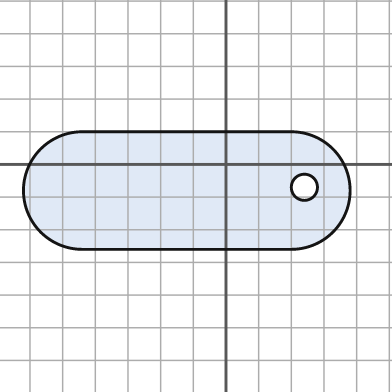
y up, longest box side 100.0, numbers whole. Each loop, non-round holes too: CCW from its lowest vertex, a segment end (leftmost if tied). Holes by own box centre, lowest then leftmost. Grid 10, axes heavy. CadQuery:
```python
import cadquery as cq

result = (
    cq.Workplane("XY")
    .moveTo(-44.0, -26.0)
    .lineTo(20.0, -26.0)
    .threePointArc((38.0, -8.0), (20.0, 10.0))
    .lineTo(-44.0, 10.0)
    .threePointArc((-62.0, -8.0), (-44.0, -26.0))
    .close()
    .moveTo(24.0, -7.0)
    .circle(4.0)
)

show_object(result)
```